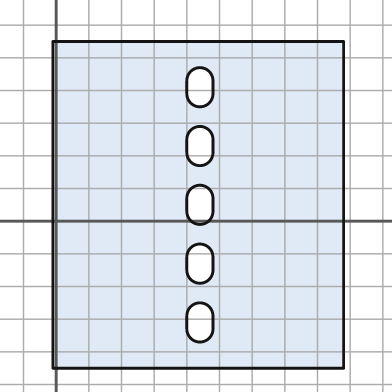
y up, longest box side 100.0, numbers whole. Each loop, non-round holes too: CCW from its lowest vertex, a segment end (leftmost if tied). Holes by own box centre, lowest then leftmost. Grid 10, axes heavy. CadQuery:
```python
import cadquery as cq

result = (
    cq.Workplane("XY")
    .moveTo(-1.0, -45.0)
    .lineTo(88.0, -45.0)
    .lineTo(88.0, 55.0)
    .lineTo(-1.0, 55.0)
    .close()
    .moveTo(40.0, -33.0)
    .threePointArc((44.0, -37.0), (48.0, -33.0))
    .lineTo(48.0, -29.0)
    .threePointArc((44.0, -25.0), (40.0, -29.0))
    .close()
    .moveTo(40.0, -15.0)
    .threePointArc((44.0, -19.0), (48.0, -15.0))
    .lineTo(48.0, -11.0)
    .threePointArc((44.0, -7.0), (40.0, -11.0))
    .close()
    .moveTo(40.0, 3.0)
    .threePointArc((44.0, -1.0), (48.0, 3.0))
    .lineTo(48.0, 7.0)
    .threePointArc((44.0, 11.0), (40.0, 7.0))
    .close()
    .moveTo(40.0, 21.0)
    .threePointArc((44.0, 17.0), (48.0, 21.0))
    .lineTo(48.0, 25.0)
    .threePointArc((44.0, 29.0), (40.0, 25.0))
    .close()
    .moveTo(40.0, 39.0)
    .threePointArc((44.0, 35.0), (48.0, 39.0))
    .lineTo(48.0, 43.0)
    .threePointArc((44.0, 47.0), (40.0, 43.0))
    .close()
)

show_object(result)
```